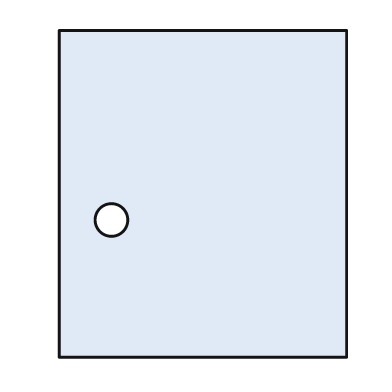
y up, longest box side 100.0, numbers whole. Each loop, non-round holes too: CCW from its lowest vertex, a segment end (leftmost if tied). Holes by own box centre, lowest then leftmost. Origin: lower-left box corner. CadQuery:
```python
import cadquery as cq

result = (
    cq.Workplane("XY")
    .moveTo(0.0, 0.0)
    .lineTo(88.0, 0.0)
    .lineTo(88.0, 100.0)
    .lineTo(0.0, 100.0)
    .close()
    .moveTo(16.0, 42.0)
    .circle(5.0)
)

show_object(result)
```